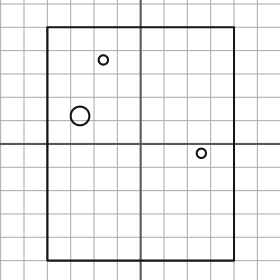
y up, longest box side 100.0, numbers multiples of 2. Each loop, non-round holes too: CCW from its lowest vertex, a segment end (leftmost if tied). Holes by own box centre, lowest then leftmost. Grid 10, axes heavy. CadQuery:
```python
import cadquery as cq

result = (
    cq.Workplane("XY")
    .moveTo(-40.0, -50.0)
    .lineTo(40.0, -50.0)
    .lineTo(40.0, 50.0)
    .lineTo(-40.0, 50.0)
    .close()
    .moveTo(26.0, -4.0)
    .circle(2.0)
    .moveTo(-26.0, 12.0)
    .circle(4.0)
    .moveTo(-16.0, 36.0)
    .circle(2.0)
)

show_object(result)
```